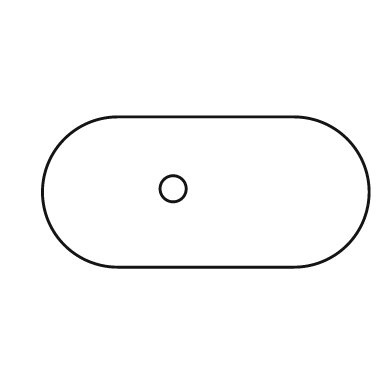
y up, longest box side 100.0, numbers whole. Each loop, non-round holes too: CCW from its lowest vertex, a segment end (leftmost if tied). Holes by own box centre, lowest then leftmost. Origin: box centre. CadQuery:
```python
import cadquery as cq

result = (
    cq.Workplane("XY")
    .moveTo(-27.0, -23.0)
    .lineTo(27.0, -23.0)
    .threePointArc((50.0, 0.0), (27.0, 23.0))
    .lineTo(-27.0, 23.0)
    .threePointArc((-50.0, 0.0), (-27.0, -23.0))
    .close()
    .moveTo(-10.0, 1.0)
    .circle(4.0)
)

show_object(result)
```